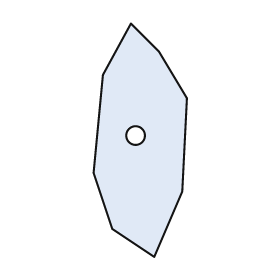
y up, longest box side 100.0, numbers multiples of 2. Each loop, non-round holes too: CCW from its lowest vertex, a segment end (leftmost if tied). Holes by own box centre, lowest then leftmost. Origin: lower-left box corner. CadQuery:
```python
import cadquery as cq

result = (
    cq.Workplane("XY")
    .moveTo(26.0, 0.0)
    .lineTo(38.0, 28.0)
    .lineTo(40.0, 68.0)
    .lineTo(28.0, 88.0)
    .lineTo(16.0, 100.0)
    .lineTo(4.0, 78.0)
    .lineTo(0.0, 36.0)
    .lineTo(8.0, 12.0)
    .close()
    .moveTo(18.0, 52.0)
    .circle(4.0)
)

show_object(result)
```